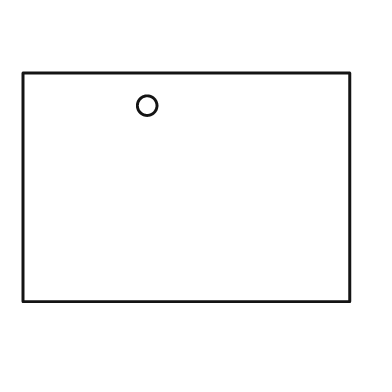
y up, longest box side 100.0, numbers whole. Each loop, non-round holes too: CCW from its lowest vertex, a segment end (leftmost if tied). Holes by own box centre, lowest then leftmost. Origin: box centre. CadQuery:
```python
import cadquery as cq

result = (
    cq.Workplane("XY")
    .moveTo(-50.0, -35.0)
    .lineTo(50.0, -35.0)
    .lineTo(50.0, 35.0)
    .lineTo(-50.0, 35.0)
    .close()
    .moveTo(-12.0, 25.0)
    .circle(3.0)
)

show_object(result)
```